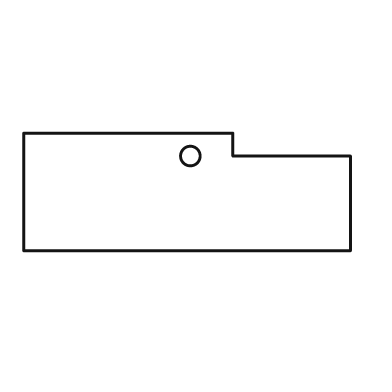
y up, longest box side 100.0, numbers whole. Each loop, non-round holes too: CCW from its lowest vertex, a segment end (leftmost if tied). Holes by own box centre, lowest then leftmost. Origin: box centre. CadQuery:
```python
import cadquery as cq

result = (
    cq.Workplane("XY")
    .moveTo(-50.0, -18.0)
    .lineTo(50.0, -18.0)
    .lineTo(50.0, 11.0)
    .lineTo(14.0, 11.0)
    .lineTo(14.0, 18.0)
    .lineTo(-50.0, 18.0)
    .close()
    .moveTo(1.0, 11.0)
    .circle(3.0)
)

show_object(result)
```